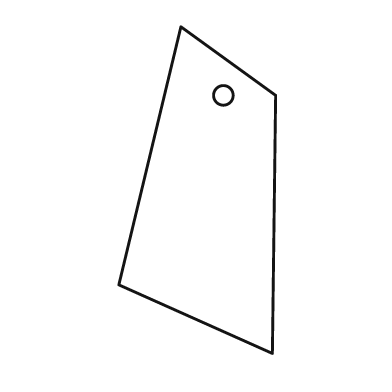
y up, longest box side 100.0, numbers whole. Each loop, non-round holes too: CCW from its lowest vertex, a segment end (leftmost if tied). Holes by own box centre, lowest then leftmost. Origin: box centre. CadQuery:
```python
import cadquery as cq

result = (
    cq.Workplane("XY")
    .moveTo(23.0, -50.0)
    .lineTo(24.0, 29.0)
    .lineTo(-5.0, 50.0)
    .lineTo(-24.0, -29.0)
    .close()
    .moveTo(8.0, 29.0)
    .circle(3.0)
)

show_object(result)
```